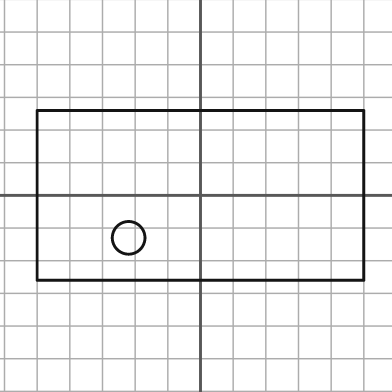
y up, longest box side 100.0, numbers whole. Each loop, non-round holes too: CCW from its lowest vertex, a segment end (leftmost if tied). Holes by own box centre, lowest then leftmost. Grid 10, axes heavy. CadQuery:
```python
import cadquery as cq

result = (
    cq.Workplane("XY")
    .moveTo(-50.0, -26.0)
    .lineTo(50.0, -26.0)
    .lineTo(50.0, 26.0)
    .lineTo(-50.0, 26.0)
    .close()
    .moveTo(-22.0, -13.0)
    .circle(5.0)
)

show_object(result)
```